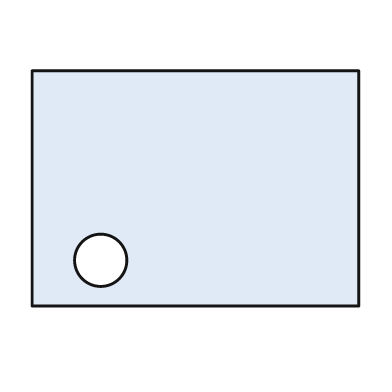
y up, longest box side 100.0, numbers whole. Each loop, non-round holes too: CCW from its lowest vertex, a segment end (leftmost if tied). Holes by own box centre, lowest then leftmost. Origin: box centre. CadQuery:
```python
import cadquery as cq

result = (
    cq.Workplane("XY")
    .moveTo(-50.0, -36.0)
    .lineTo(50.0, -36.0)
    .lineTo(50.0, 36.0)
    .lineTo(-50.0, 36.0)
    .close()
    .moveTo(-29.0, -22.0)
    .circle(8.0)
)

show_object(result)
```